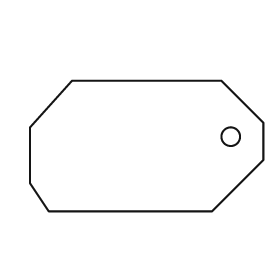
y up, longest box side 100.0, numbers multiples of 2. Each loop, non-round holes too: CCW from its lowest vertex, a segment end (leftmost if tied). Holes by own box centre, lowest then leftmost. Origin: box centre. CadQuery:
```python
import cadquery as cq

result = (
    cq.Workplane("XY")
    .moveTo(-42.0, -28.0)
    .lineTo(28.0, -28.0)
    .lineTo(50.0, -6.0)
    .lineTo(50.0, 10.0)
    .lineTo(32.0, 28.0)
    .lineTo(-32.0, 28.0)
    .lineTo(-50.0, 8.0)
    .lineTo(-50.0, -16.0)
    .close()
    .moveTo(36.0, 4.0)
    .circle(4.0)
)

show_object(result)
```